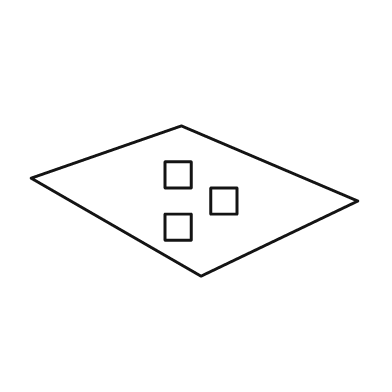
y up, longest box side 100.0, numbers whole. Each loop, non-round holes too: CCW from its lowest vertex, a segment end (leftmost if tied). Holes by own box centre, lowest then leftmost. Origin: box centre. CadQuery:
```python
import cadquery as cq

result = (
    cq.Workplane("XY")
    .moveTo(2.0, -23.0)
    .lineTo(50.0, 0.0)
    .lineTo(-4.0, 23.0)
    .lineTo(-50.0, 7.0)
    .close()
    .moveTo(-9.0, -12.0)
    .lineTo(-1.0, -12.0)
    .lineTo(-1.0, -4.0)
    .lineTo(-9.0, -4.0)
    .close()
    .moveTo(5.0, -4.0)
    .lineTo(13.0, -4.0)
    .lineTo(13.0, 4.0)
    .lineTo(5.0, 4.0)
    .close()
    .moveTo(-9.0, 4.0)
    .lineTo(-1.0, 4.0)
    .lineTo(-1.0, 12.0)
    .lineTo(-9.0, 12.0)
    .close()
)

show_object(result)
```